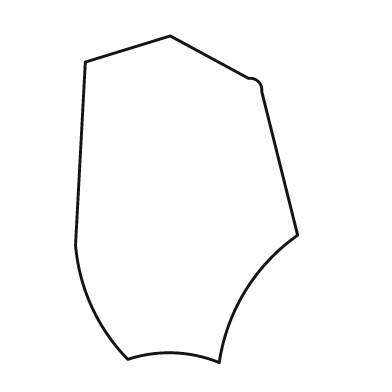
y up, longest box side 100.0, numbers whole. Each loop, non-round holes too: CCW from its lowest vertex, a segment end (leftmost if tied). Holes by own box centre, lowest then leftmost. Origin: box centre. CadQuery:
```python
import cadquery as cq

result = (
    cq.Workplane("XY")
    .moveTo(10.0, -50.0)
    .threePointArc((18.0, -28.0), (34.0, -11.0))
    .lineTo(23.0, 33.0)
    .threePointArc((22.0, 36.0), (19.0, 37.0))
    .lineTo(-5.0, 50.0)
    .lineTo(-31.0, 42.0)
    .lineTo(-34.0, -14.0)
    .threePointArc((-29.0, -33.0), (-18.0, -49.0))
    .threePointArc((-4.0, -47.0), (10.0, -50.0))
    .close()
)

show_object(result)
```